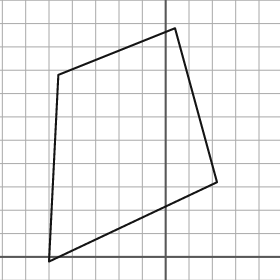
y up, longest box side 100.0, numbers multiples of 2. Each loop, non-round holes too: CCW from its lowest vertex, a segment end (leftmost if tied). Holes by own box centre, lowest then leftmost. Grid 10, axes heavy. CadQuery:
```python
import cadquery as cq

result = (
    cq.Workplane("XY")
    .moveTo(-50.0, -2.0)
    .lineTo(22.0, 32.0)
    .lineTo(4.0, 98.0)
    .lineTo(-46.0, 78.0)
    .close()
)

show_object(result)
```